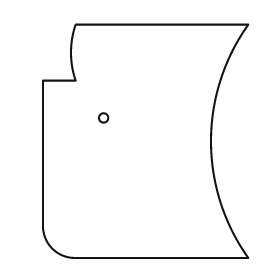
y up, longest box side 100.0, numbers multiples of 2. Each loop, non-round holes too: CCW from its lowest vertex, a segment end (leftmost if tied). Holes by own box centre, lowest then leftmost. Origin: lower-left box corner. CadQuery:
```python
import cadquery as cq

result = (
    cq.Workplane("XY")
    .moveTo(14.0, 0.0)
    .lineTo(88.0, 0.0)
    .threePointArc((72.0, 50.0), (88.0, 100.0))
    .lineTo(14.0, 100.0)
    .threePointArc((12.0, 88.0), (14.0, 76.0))
    .lineTo(0.0, 76.0)
    .lineTo(0.0, 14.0)
    .threePointArc((4.0, 4.0), (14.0, 0.0))
    .close()
    .moveTo(26.0, 60.0)
    .circle(2.0)
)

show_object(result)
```